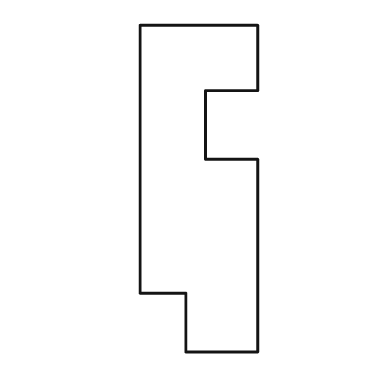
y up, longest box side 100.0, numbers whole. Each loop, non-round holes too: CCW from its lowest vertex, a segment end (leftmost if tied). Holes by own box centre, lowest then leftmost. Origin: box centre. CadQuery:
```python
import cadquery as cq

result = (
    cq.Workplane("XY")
    .moveTo(-4.0, -50.0)
    .lineTo(18.0, -50.0)
    .lineTo(18.0, 9.0)
    .lineTo(2.0, 9.0)
    .lineTo(2.0, 30.0)
    .lineTo(18.0, 30.0)
    .lineTo(18.0, 50.0)
    .lineTo(-18.0, 50.0)
    .lineTo(-18.0, -32.0)
    .lineTo(-4.0, -32.0)
    .close()
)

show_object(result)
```